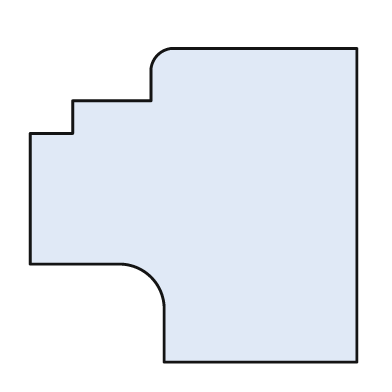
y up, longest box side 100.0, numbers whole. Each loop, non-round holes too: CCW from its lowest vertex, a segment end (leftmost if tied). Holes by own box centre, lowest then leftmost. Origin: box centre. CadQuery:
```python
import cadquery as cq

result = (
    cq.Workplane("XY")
    .moveTo(-9.0, -48.0)
    .lineTo(50.0, -48.0)
    .lineTo(50.0, 48.0)
    .lineTo(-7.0, 48.0)
    .threePointArc((-11.0, 46.0), (-13.0, 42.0))
    .lineTo(-13.0, 32.0)
    .lineTo(-37.0, 32.0)
    .lineTo(-37.0, 22.0)
    .lineTo(-50.0, 22.0)
    .lineTo(-50.0, -18.0)
    .lineTo(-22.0, -18.0)
    .threePointArc((-13.0, -22.0), (-9.0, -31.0))
    .close()
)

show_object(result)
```